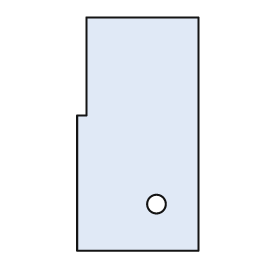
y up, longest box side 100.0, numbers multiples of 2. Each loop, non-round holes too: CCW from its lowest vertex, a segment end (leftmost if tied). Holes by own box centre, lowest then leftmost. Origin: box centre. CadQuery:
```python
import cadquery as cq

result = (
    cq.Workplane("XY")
    .moveTo(-26.0, -50.0)
    .lineTo(26.0, -50.0)
    .lineTo(26.0, 50.0)
    .lineTo(-22.0, 50.0)
    .lineTo(-22.0, 8.0)
    .lineTo(-26.0, 8.0)
    .close()
    .moveTo(8.0, -30.0)
    .circle(4.0)
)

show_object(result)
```